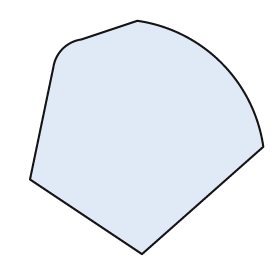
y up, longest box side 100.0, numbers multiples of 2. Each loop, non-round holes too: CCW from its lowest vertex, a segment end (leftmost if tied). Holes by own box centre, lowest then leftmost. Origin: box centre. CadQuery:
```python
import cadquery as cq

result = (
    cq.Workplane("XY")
    .moveTo(-2.0, -50.0)
    .lineTo(50.0, -4.0)
    .threePointArc((32.0, 32.0), (-4.0, 50.0))
    .lineTo(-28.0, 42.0)
    .threePointArc((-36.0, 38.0), (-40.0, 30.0))
    .lineTo(-50.0, -18.0)
    .close()
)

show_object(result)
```